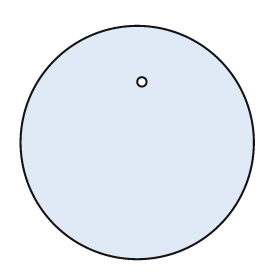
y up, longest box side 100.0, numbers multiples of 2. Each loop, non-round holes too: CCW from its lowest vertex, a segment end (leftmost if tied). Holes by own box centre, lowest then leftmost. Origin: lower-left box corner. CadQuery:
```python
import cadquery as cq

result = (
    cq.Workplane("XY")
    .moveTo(50.0, 50.0)
    .circle(50.0)
    .moveTo(52.0, 76.0)
    .circle(2.0)
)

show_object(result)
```